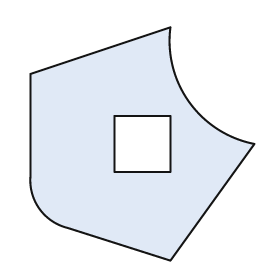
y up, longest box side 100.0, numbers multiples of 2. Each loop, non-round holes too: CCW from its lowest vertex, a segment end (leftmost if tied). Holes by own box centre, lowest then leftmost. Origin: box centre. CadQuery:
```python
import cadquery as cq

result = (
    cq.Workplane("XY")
    .moveTo(12.0, -50.0)
    .lineTo(48.0, 0.0)
    .threePointArc((20.0, 18.0), (12.0, 50.0))
    .lineTo(-48.0, 30.0)
    .lineTo(-48.0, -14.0)
    .threePointArc((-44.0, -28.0), (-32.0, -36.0))
    .close()
    .moveTo(-12.0, -12.0)
    .lineTo(12.0, -12.0)
    .lineTo(12.0, 12.0)
    .lineTo(-12.0, 12.0)
    .close()
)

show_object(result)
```